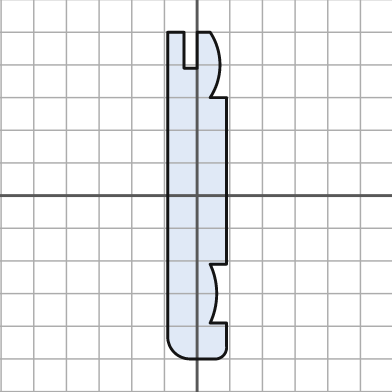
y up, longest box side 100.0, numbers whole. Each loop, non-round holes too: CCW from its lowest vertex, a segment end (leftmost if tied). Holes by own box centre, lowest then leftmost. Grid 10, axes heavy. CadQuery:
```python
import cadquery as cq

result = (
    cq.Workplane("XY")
    .moveTo(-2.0, -50.0)
    .lineTo(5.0, -50.0)
    .threePointArc((8.0, -49.0), (9.0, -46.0))
    .lineTo(9.0, -39.0)
    .lineTo(4.0, -39.0)
    .threePointArc((6.0, -30.0), (4.0, -21.0))
    .lineTo(9.0, -21.0)
    .lineTo(9.0, 30.0)
    .lineTo(4.0, 30.0)
    .threePointArc((7.0, 40.0), (4.0, 50.0))
    .lineTo(0.0, 50.0)
    .lineTo(0.0, 39.0)
    .lineTo(-4.0, 39.0)
    .lineTo(-4.0, 50.0)
    .lineTo(-9.0, 50.0)
    .lineTo(-9.0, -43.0)
    .threePointArc((-7.0, -48.0), (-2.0, -50.0))
    .close()
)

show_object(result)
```